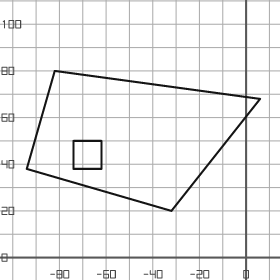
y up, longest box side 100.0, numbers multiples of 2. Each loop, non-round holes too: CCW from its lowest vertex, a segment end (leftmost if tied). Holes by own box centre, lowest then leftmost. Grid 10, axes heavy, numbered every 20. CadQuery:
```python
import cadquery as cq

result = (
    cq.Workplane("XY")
    .moveTo(-32.0, 20.0)
    .lineTo(6.0, 68.0)
    .lineTo(-82.0, 80.0)
    .lineTo(-94.0, 38.0)
    .close()
    .moveTo(-74.0, 38.0)
    .lineTo(-62.0, 38.0)
    .lineTo(-62.0, 50.0)
    .lineTo(-74.0, 50.0)
    .close()
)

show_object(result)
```